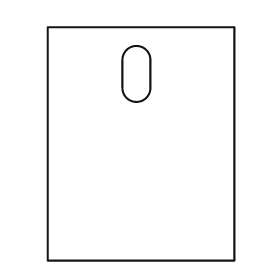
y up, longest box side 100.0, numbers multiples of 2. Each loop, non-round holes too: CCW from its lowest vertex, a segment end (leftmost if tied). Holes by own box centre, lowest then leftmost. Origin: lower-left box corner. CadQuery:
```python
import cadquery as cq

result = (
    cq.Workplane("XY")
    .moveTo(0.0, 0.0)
    .lineTo(80.0, 0.0)
    .lineTo(80.0, 100.0)
    .lineTo(0.0, 100.0)
    .close()
    .moveTo(32.0, 74.0)
    .threePointArc((38.0, 68.0), (44.0, 74.0))
    .lineTo(44.0, 86.0)
    .threePointArc((38.0, 92.0), (32.0, 86.0))
    .close()
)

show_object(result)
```